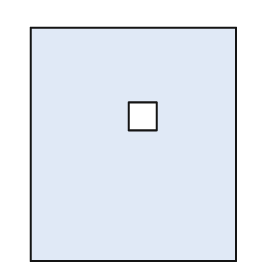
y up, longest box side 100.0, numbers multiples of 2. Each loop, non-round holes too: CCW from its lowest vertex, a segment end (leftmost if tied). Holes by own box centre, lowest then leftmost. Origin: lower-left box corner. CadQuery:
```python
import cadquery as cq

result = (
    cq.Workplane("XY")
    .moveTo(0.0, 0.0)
    .lineTo(88.0, 0.0)
    .lineTo(88.0, 100.0)
    .lineTo(0.0, 100.0)
    .close()
    .moveTo(42.0, 56.0)
    .lineTo(54.0, 56.0)
    .lineTo(54.0, 68.0)
    .lineTo(42.0, 68.0)
    .close()
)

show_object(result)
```